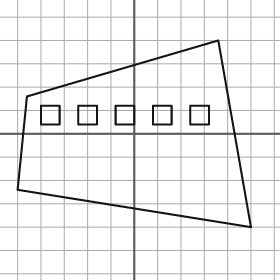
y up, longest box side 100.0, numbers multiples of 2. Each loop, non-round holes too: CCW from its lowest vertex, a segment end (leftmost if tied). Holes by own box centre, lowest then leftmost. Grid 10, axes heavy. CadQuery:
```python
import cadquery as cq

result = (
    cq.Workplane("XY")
    .moveTo(50.0, -40.0)
    .lineTo(36.0, 40.0)
    .lineTo(-46.0, 16.0)
    .lineTo(-50.0, -24.0)
    .close()
    .moveTo(-40.0, 4.0)
    .lineTo(-32.0, 4.0)
    .lineTo(-32.0, 12.0)
    .lineTo(-40.0, 12.0)
    .close()
    .moveTo(-24.0, 4.0)
    .lineTo(-16.0, 4.0)
    .lineTo(-16.0, 12.0)
    .lineTo(-24.0, 12.0)
    .close()
    .moveTo(-8.0, 4.0)
    .lineTo(0.0, 4.0)
    .lineTo(0.0, 12.0)
    .lineTo(-8.0, 12.0)
    .close()
    .moveTo(8.0, 4.0)
    .lineTo(16.0, 4.0)
    .lineTo(16.0, 12.0)
    .lineTo(8.0, 12.0)
    .close()
    .moveTo(24.0, 4.0)
    .lineTo(32.0, 4.0)
    .lineTo(32.0, 12.0)
    .lineTo(24.0, 12.0)
    .close()
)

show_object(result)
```